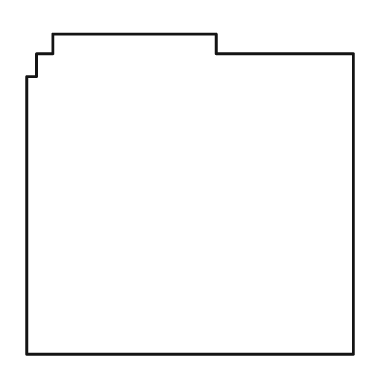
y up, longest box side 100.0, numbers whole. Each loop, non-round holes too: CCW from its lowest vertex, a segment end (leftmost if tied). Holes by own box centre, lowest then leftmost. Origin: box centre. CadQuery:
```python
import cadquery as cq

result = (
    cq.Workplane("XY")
    .moveTo(-50.0, -49.0)
    .lineTo(50.0, -49.0)
    .lineTo(50.0, 43.0)
    .lineTo(8.0, 43.0)
    .lineTo(8.0, 49.0)
    .lineTo(-42.0, 49.0)
    .lineTo(-42.0, 43.0)
    .lineTo(-47.0, 43.0)
    .lineTo(-47.0, 36.0)
    .lineTo(-50.0, 36.0)
    .close()
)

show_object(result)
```